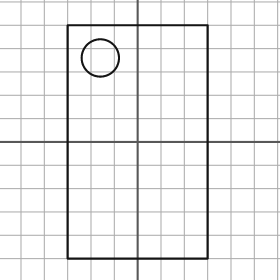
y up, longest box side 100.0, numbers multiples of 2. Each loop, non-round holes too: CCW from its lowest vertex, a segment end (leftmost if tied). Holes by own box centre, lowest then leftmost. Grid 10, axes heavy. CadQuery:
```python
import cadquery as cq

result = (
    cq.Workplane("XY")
    .moveTo(-30.0, -50.0)
    .lineTo(30.0, -50.0)
    .lineTo(30.0, 50.0)
    .lineTo(-30.0, 50.0)
    .close()
    .moveTo(-16.0, 36.0)
    .circle(8.0)
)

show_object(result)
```